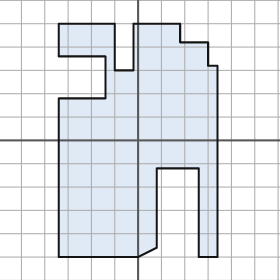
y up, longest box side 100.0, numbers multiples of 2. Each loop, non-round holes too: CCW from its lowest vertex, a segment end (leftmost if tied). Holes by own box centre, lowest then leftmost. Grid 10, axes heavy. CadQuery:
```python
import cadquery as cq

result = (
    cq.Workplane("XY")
    .moveTo(-34.0, -50.0)
    .lineTo(0.0, -50.0)
    .lineTo(8.0, -46.0)
    .lineTo(8.0, -12.0)
    .lineTo(26.0, -12.0)
    .lineTo(26.0, -50.0)
    .lineTo(34.0, -50.0)
    .lineTo(34.0, 32.0)
    .lineTo(30.0, 32.0)
    .lineTo(30.0, 42.0)
    .lineTo(18.0, 42.0)
    .lineTo(18.0, 50.0)
    .lineTo(-2.0, 50.0)
    .lineTo(-2.0, 30.0)
    .lineTo(-10.0, 30.0)
    .lineTo(-10.0, 50.0)
    .lineTo(-34.0, 50.0)
    .lineTo(-34.0, 36.0)
    .lineTo(-14.0, 36.0)
    .lineTo(-14.0, 18.0)
    .lineTo(-34.0, 18.0)
    .close()
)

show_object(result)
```